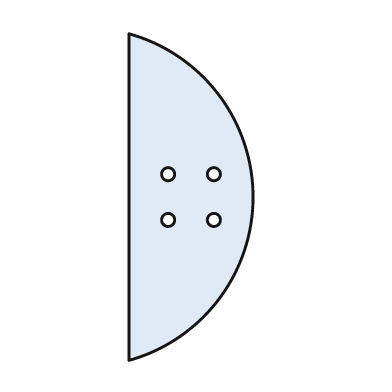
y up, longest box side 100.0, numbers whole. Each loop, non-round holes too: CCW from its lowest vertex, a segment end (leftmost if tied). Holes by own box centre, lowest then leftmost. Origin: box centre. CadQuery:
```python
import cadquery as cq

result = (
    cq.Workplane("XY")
    .moveTo(-19.0, -50.0)
    .threePointArc((19.0, 0.0), (-19.0, 50.0))
    .close()
    .moveTo(-7.0, -7.0)
    .circle(2.0)
    .moveTo(7.0, -7.0)
    .circle(2.0)
    .moveTo(-7.0, 7.0)
    .circle(2.0)
    .moveTo(7.0, 7.0)
    .circle(2.0)
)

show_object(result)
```